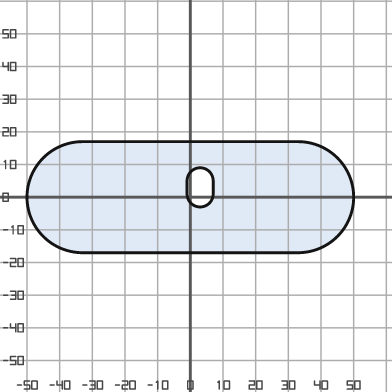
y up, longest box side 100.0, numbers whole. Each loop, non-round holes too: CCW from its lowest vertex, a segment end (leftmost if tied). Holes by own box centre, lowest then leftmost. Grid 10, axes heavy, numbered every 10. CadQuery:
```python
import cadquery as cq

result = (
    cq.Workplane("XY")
    .moveTo(-33.0, -17.0)
    .lineTo(33.0, -17.0)
    .threePointArc((50.0, 0.0), (33.0, 17.0))
    .lineTo(-33.0, 17.0)
    .threePointArc((-50.0, 0.0), (-33.0, -17.0))
    .close()
    .moveTo(-1.0, 1.0)
    .threePointArc((3.0, -3.0), (7.0, 1.0))
    .lineTo(7.0, 5.0)
    .threePointArc((3.0, 9.0), (-1.0, 5.0))
    .close()
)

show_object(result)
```